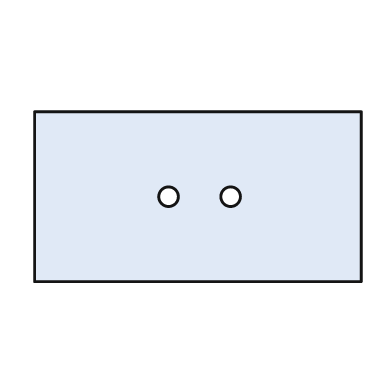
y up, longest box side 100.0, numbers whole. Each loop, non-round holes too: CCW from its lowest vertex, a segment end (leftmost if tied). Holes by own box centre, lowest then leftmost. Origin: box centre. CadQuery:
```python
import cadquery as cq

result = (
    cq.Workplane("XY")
    .moveTo(-50.0, -26.0)
    .lineTo(50.0, -26.0)
    .lineTo(50.0, 26.0)
    .lineTo(-50.0, 26.0)
    .close()
    .moveTo(-9.0, 0.0)
    .circle(3.0)
    .moveTo(10.0, 0.0)
    .circle(3.0)
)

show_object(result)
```